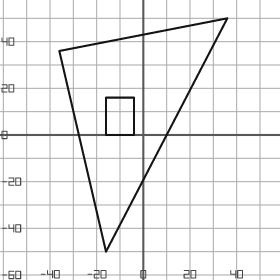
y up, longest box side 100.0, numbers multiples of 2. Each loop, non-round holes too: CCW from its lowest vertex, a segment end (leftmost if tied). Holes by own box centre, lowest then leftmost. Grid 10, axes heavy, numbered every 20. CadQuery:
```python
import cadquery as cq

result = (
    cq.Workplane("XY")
    .moveTo(-16.0, -50.0)
    .lineTo(36.0, 50.0)
    .lineTo(-36.0, 36.0)
    .close()
    .moveTo(-16.0, 0.0)
    .lineTo(-4.0, 0.0)
    .lineTo(-4.0, 16.0)
    .lineTo(-16.0, 16.0)
    .close()
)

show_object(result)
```